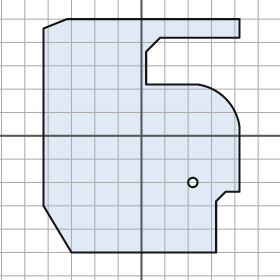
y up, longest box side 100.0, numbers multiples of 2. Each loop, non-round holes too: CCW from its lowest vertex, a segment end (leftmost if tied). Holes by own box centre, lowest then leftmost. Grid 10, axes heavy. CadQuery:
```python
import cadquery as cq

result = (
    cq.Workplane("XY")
    .moveTo(-30.0, -50.0)
    .lineTo(32.0, -50.0)
    .lineTo(32.0, -28.0)
    .lineTo(36.0, -24.0)
    .lineTo(42.0, -24.0)
    .lineTo(42.0, 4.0)
    .threePointArc((36.0, 16.0), (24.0, 22.0))
    .lineTo(2.0, 22.0)
    .lineTo(2.0, 36.0)
    .lineTo(8.0, 42.0)
    .lineTo(42.0, 42.0)
    .lineTo(42.0, 50.0)
    .lineTo(-32.0, 50.0)
    .lineTo(-42.0, 46.0)
    .lineTo(-42.0, -30.0)
    .close()
    .moveTo(22.0, -20.0)
    .circle(2.0)
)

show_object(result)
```